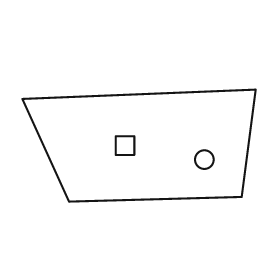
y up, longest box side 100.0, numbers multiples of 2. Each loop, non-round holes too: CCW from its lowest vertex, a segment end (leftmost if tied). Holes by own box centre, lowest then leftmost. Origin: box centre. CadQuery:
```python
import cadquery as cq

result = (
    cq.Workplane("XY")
    .moveTo(-30.0, -24.0)
    .lineTo(44.0, -22.0)
    .lineTo(50.0, 24.0)
    .lineTo(-50.0, 20.0)
    .close()
    .moveTo(28.0, -6.0)
    .circle(4.0)
    .moveTo(-10.0, -4.0)
    .lineTo(-2.0, -4.0)
    .lineTo(-2.0, 4.0)
    .lineTo(-10.0, 4.0)
    .close()
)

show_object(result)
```